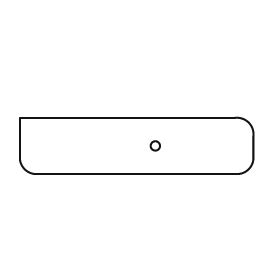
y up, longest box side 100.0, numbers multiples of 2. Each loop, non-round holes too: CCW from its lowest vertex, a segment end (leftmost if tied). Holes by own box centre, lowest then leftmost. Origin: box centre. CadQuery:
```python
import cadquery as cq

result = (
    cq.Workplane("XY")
    .moveTo(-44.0, -12.0)
    .lineTo(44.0, -12.0)
    .threePointArc((48.0, -10.0), (50.0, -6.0))
    .lineTo(50.0, 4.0)
    .threePointArc((48.0, 10.0), (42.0, 12.0))
    .lineTo(-50.0, 12.0)
    .lineTo(-50.0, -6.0)
    .threePointArc((-48.0, -10.0), (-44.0, -12.0))
    .close()
    .moveTo(8.0, 0.0)
    .circle(2.0)
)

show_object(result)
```